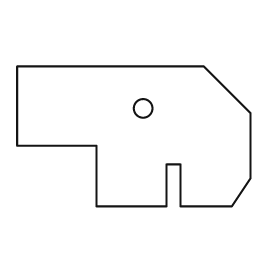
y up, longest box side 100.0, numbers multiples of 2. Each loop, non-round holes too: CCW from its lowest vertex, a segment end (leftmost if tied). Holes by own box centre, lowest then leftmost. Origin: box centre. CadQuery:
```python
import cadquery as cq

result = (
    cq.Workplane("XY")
    .moveTo(-16.0, -30.0)
    .lineTo(14.0, -30.0)
    .lineTo(14.0, -12.0)
    .lineTo(20.0, -12.0)
    .lineTo(20.0, -30.0)
    .lineTo(42.0, -30.0)
    .lineTo(50.0, -18.0)
    .lineTo(50.0, 10.0)
    .lineTo(30.0, 30.0)
    .lineTo(-50.0, 30.0)
    .lineTo(-50.0, -4.0)
    .lineTo(-16.0, -4.0)
    .close()
    .moveTo(4.0, 12.0)
    .circle(4.0)
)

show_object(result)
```